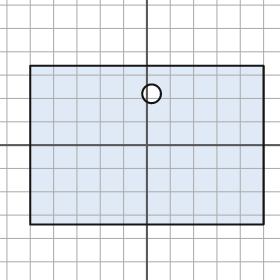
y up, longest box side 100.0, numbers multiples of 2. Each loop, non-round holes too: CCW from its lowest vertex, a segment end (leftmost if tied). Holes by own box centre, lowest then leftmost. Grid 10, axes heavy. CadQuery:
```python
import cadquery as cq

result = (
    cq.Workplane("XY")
    .moveTo(-50.0, -34.0)
    .lineTo(50.0, -34.0)
    .lineTo(50.0, 34.0)
    .lineTo(-50.0, 34.0)
    .close()
    .moveTo(2.0, 22.0)
    .circle(4.0)
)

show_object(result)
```